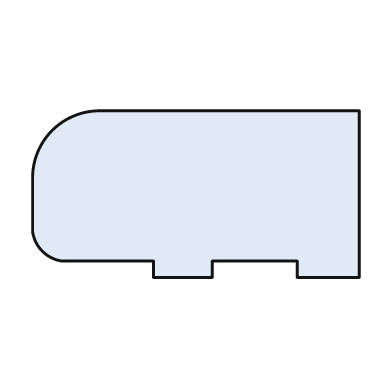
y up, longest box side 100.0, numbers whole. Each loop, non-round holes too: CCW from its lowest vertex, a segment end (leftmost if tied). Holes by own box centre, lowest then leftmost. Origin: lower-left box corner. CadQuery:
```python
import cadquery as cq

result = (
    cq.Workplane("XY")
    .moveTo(37.0, 0.0)
    .lineTo(55.0, 0.0)
    .lineTo(55.0, 5.0)
    .lineTo(81.0, 5.0)
    .lineTo(81.0, 0.0)
    .lineTo(100.0, 0.0)
    .lineTo(100.0, 51.0)
    .lineTo(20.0, 51.0)
    .threePointArc((6.0, 45.0), (0.0, 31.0))
    .lineTo(0.0, 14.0)
    .threePointArc((3.0, 8.0), (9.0, 5.0))
    .lineTo(37.0, 5.0)
    .close()
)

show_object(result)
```